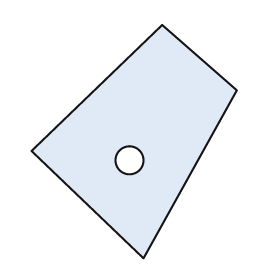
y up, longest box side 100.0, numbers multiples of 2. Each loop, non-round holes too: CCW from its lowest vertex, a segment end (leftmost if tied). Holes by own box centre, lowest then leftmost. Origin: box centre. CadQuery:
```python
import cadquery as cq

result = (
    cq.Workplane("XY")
    .moveTo(4.0, -50.0)
    .lineTo(44.0, 22.0)
    .lineTo(12.0, 50.0)
    .lineTo(-44.0, -4.0)
    .close()
    .moveTo(-2.0, -8.0)
    .circle(6.0)
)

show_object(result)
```